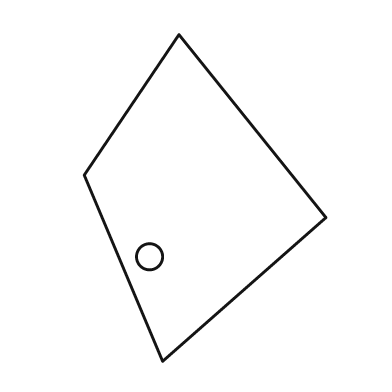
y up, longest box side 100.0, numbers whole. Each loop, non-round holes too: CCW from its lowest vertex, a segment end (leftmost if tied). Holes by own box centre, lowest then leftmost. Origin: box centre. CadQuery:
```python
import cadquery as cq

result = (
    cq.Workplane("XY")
    .moveTo(-13.0, -50.0)
    .lineTo(37.0, -6.0)
    .lineTo(-8.0, 50.0)
    .lineTo(-37.0, 7.0)
    .close()
    .moveTo(-17.0, -18.0)
    .circle(4.0)
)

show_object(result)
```